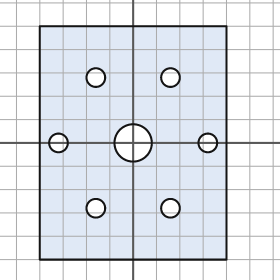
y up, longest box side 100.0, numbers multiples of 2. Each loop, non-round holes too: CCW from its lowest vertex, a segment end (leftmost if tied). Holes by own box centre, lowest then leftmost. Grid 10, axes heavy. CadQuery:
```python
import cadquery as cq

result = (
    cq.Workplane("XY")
    .moveTo(-40.0, -50.0)
    .lineTo(40.0, -50.0)
    .lineTo(40.0, 50.0)
    .lineTo(-40.0, 50.0)
    .close()
    .moveTo(-16.0, -28.0)
    .circle(4.0)
    .moveTo(16.0, -28.0)
    .circle(4.0)
    .moveTo(-32.0, 0.0)
    .circle(4.0)
    .moveTo(0.0, 0.0)
    .circle(8.0)
    .moveTo(32.0, 0.0)
    .circle(4.0)
    .moveTo(-16.0, 28.0)
    .circle(4.0)
    .moveTo(16.0, 28.0)
    .circle(4.0)
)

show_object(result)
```